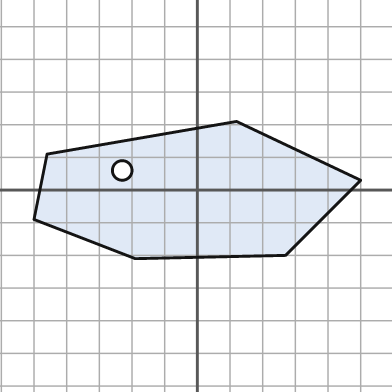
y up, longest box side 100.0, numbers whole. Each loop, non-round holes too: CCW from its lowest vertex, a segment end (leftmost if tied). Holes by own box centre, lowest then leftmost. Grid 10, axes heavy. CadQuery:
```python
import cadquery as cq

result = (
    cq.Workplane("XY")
    .moveTo(-19.0, -21.0)
    .lineTo(27.0, -20.0)
    .lineTo(50.0, 3.0)
    .lineTo(12.0, 21.0)
    .lineTo(-46.0, 11.0)
    .lineTo(-50.0, -9.0)
    .close()
    .moveTo(-23.0, 6.0)
    .circle(3.0)
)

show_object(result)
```